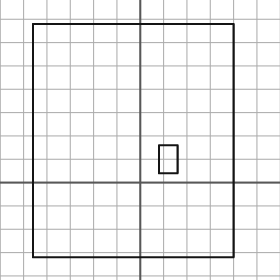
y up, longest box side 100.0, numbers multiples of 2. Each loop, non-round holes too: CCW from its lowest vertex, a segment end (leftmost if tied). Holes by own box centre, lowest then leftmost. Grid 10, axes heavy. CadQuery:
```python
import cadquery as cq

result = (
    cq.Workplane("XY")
    .moveTo(-46.0, -32.0)
    .lineTo(40.0, -32.0)
    .lineTo(40.0, 68.0)
    .lineTo(-46.0, 68.0)
    .close()
    .moveTo(8.0, 4.0)
    .lineTo(16.0, 4.0)
    .lineTo(16.0, 16.0)
    .lineTo(8.0, 16.0)
    .close()
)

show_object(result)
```